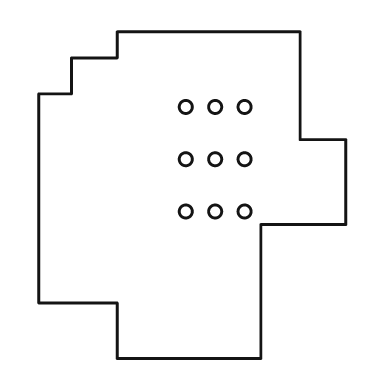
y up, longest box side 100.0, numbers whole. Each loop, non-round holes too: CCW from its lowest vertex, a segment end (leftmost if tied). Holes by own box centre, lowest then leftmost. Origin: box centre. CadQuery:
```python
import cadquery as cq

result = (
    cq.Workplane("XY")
    .moveTo(-23.0, -50.0)
    .lineTo(21.0, -50.0)
    .lineTo(21.0, -9.0)
    .lineTo(47.0, -9.0)
    .lineTo(47.0, 17.0)
    .lineTo(33.0, 17.0)
    .lineTo(33.0, 50.0)
    .lineTo(-23.0, 50.0)
    .lineTo(-23.0, 42.0)
    .lineTo(-37.0, 42.0)
    .lineTo(-37.0, 31.0)
    .lineTo(-47.0, 31.0)
    .lineTo(-47.0, -33.0)
    .lineTo(-23.0, -33.0)
    .close()
    .moveTo(-2.0, -5.0)
    .circle(2.0)
    .moveTo(7.0, -5.0)
    .circle(2.0)
    .moveTo(16.0, -5.0)
    .circle(2.0)
    .moveTo(-2.0, 11.0)
    .circle(2.0)
    .moveTo(7.0, 11.0)
    .circle(2.0)
    .moveTo(16.0, 11.0)
    .circle(2.0)
    .moveTo(-2.0, 27.0)
    .circle(2.0)
    .moveTo(7.0, 27.0)
    .circle(2.0)
    .moveTo(16.0, 27.0)
    .circle(2.0)
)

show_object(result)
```